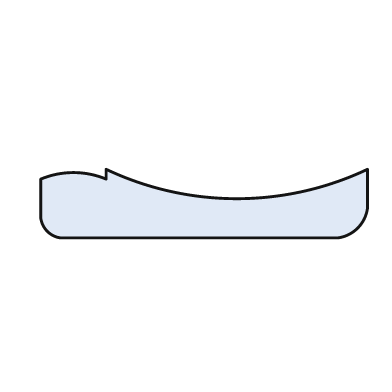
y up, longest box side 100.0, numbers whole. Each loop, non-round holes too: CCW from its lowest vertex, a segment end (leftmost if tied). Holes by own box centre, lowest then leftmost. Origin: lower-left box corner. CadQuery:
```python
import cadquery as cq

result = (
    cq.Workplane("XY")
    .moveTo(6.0, 0.0)
    .lineTo(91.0, 0.0)
    .threePointArc((97.0, 3.0), (100.0, 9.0))
    .lineTo(100.0, 21.0)
    .threePointArc((60.0, 12.0), (20.0, 21.0))
    .lineTo(20.0, 18.0)
    .threePointArc((10.0, 20.0), (0.0, 18.0))
    .lineTo(0.0, 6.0)
    .threePointArc((2.0, 2.0), (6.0, 0.0))
    .close()
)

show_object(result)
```